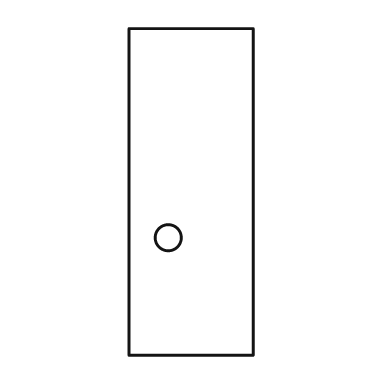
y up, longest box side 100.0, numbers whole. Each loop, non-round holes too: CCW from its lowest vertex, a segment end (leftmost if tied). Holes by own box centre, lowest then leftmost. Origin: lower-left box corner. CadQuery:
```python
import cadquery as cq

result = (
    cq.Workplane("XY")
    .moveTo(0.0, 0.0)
    .lineTo(38.0, 0.0)
    .lineTo(38.0, 100.0)
    .lineTo(0.0, 100.0)
    .close()
    .moveTo(12.0, 36.0)
    .circle(4.0)
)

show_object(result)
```